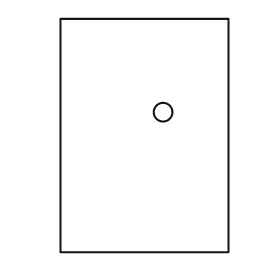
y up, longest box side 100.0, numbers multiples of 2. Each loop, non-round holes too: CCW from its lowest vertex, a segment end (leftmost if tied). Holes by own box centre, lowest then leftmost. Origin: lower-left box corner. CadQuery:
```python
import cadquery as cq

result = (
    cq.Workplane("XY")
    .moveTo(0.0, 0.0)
    .lineTo(72.0, 0.0)
    .lineTo(72.0, 100.0)
    .lineTo(0.0, 100.0)
    .close()
    .moveTo(44.0, 60.0)
    .circle(4.0)
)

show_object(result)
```